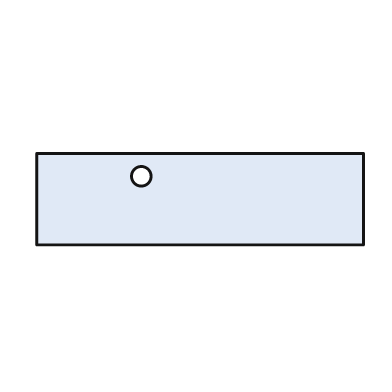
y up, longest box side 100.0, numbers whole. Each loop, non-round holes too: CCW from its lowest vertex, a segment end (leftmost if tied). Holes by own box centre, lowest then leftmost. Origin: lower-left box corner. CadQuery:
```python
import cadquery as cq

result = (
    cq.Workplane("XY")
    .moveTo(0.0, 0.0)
    .lineTo(100.0, 0.0)
    .lineTo(100.0, 28.0)
    .lineTo(0.0, 28.0)
    .close()
    .moveTo(32.0, 21.0)
    .circle(3.0)
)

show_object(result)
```